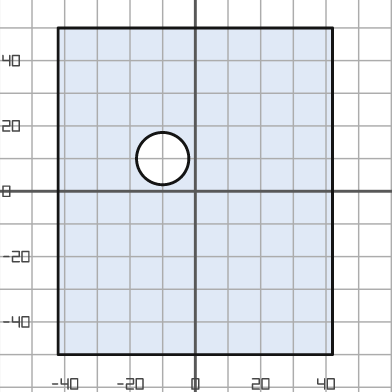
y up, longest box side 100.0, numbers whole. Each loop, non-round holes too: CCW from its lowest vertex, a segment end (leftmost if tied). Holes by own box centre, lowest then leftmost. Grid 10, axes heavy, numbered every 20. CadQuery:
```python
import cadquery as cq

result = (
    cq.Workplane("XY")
    .moveTo(-42.0, -50.0)
    .lineTo(42.0, -50.0)
    .lineTo(42.0, 50.0)
    .lineTo(-42.0, 50.0)
    .close()
    .moveTo(-10.0, 10.0)
    .circle(8.0)
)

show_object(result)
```